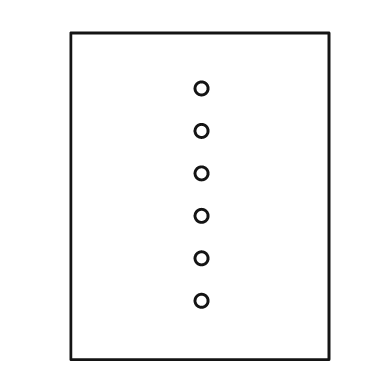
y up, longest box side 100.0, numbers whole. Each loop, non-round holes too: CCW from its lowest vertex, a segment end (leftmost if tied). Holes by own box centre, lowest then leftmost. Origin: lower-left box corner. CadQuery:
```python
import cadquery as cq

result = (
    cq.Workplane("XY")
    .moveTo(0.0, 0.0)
    .lineTo(79.0, 0.0)
    .lineTo(79.0, 100.0)
    .lineTo(0.0, 100.0)
    .close()
    .moveTo(40.0, 18.0)
    .circle(2.0)
    .moveTo(40.0, 31.0)
    .circle(2.0)
    .moveTo(40.0, 44.0)
    .circle(2.0)
    .moveTo(40.0, 57.0)
    .circle(2.0)
    .moveTo(40.0, 70.0)
    .circle(2.0)
    .moveTo(40.0, 83.0)
    .circle(2.0)
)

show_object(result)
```